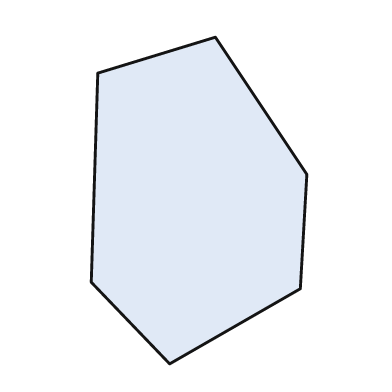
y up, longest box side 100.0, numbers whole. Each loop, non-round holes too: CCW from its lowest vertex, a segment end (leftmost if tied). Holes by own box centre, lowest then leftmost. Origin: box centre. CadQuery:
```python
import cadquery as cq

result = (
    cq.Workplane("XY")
    .moveTo(-9.0, -50.0)
    .lineTo(31.0, -27.0)
    .lineTo(33.0, 8.0)
    .lineTo(5.0, 50.0)
    .lineTo(-31.0, 39.0)
    .lineTo(-33.0, -25.0)
    .close()
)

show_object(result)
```